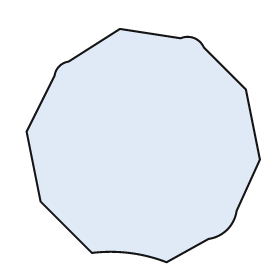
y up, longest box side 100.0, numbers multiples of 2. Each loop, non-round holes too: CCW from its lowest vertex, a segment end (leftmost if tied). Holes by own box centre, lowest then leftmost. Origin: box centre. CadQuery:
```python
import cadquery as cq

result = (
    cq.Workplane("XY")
    .moveTo(10.0, -50.0)
    .lineTo(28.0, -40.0)
    .threePointArc((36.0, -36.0), (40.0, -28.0))
    .lineTo(50.0, -6.0)
    .lineTo(44.0, 24.0)
    .lineTo(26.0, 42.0)
    .threePointArc((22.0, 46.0), (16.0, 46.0))
    .lineTo(-10.0, 50.0)
    .lineTo(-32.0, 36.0)
    .threePointArc((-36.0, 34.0), (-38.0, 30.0))
    .lineTo(-50.0, 6.0)
    .lineTo(-44.0, -24.0)
    .lineTo(-22.0, -46.0)
    .threePointArc((-6.0, -46.0), (10.0, -50.0))
    .close()
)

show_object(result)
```